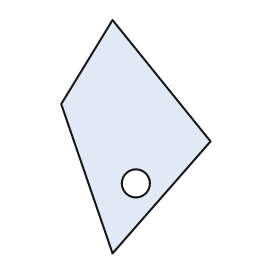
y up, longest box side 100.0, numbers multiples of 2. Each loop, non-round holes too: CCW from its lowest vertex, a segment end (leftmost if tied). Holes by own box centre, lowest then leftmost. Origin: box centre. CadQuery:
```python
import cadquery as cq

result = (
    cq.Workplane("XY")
    .moveTo(-10.0, -50.0)
    .lineTo(32.0, -2.0)
    .lineTo(-10.0, 50.0)
    .lineTo(-32.0, 14.0)
    .close()
    .moveTo(0.0, -20.0)
    .circle(6.0)
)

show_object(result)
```